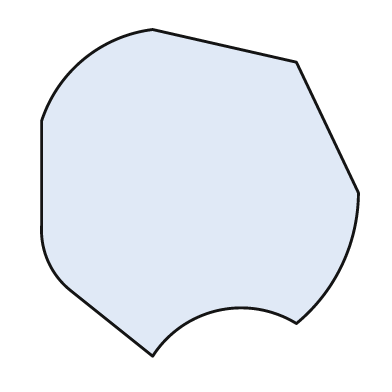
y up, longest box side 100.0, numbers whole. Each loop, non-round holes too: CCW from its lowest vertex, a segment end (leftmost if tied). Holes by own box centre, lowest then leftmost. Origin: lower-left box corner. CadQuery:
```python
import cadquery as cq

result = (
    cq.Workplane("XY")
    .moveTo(34.0, 0.0)
    .threePointArc((54.0, 14.0), (78.0, 10.0))
    .threePointArc((92.0, 28.0), (97.0, 50.0))
    .lineTo(78.0, 90.0)
    .lineTo(34.0, 100.0)
    .threePointArc((13.0, 91.0), (0.0, 72.0))
    .lineTo(0.0, 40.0)
    .threePointArc((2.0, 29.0), (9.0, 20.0))
    .close()
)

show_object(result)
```